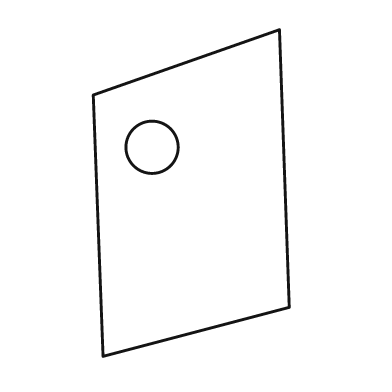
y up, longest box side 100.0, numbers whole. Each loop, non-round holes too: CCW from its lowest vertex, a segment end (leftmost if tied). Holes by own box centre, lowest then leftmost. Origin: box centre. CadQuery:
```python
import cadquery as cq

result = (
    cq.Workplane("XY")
    .moveTo(-27.0, -50.0)
    .lineTo(30.0, -35.0)
    .lineTo(27.0, 50.0)
    .lineTo(-30.0, 30.0)
    .close()
    .moveTo(-12.0, 14.0)
    .circle(8.0)
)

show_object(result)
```